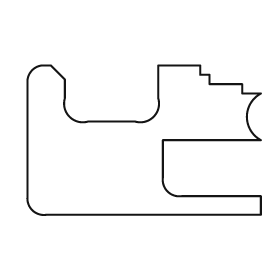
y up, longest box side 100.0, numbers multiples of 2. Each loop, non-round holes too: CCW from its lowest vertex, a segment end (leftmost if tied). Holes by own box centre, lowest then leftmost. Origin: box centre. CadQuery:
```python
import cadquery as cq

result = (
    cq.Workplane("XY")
    .moveTo(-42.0, -32.0)
    .lineTo(50.0, -32.0)
    .lineTo(50.0, -24.0)
    .lineTo(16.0, -24.0)
    .threePointArc((10.0, -22.0), (8.0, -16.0))
    .lineTo(8.0, 0.0)
    .lineTo(50.0, 0.0)
    .threePointArc((44.0, 10.0), (50.0, 20.0))
    .lineTo(42.0, 20.0)
    .lineTo(42.0, 24.0)
    .lineTo(28.0, 24.0)
    .lineTo(28.0, 28.0)
    .lineTo(24.0, 28.0)
    .lineTo(24.0, 32.0)
    .lineTo(6.0, 32.0)
    .lineTo(6.0, 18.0)
    .threePointArc((4.0, 10.0), (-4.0, 8.0))
    .lineTo(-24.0, 8.0)
    .threePointArc((-32.0, 10.0), (-34.0, 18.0))
    .lineTo(-34.0, 26.0)
    .lineTo(-40.0, 32.0)
    .lineTo(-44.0, 32.0)
    .threePointArc((-48.0, 30.0), (-50.0, 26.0))
    .lineTo(-50.0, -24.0)
    .threePointArc((-48.0, -30.0), (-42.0, -32.0))
    .close()
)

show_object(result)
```